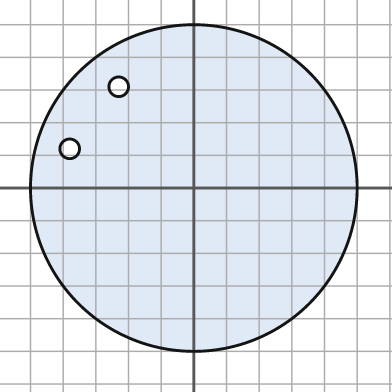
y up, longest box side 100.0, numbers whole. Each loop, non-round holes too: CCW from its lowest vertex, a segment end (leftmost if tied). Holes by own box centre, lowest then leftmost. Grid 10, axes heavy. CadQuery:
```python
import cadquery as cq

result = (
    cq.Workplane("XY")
    .moveTo(0.0, 0.0)
    .circle(50.0)
    .moveTo(-38.0, 12.0)
    .circle(3.0)
    .moveTo(-23.0, 31.0)
    .circle(3.0)
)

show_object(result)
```